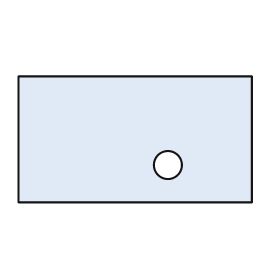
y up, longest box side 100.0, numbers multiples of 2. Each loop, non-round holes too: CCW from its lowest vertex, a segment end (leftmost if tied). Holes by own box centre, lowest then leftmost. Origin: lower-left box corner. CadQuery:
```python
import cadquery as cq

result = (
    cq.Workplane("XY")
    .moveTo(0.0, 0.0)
    .lineTo(100.0, 0.0)
    .lineTo(100.0, 54.0)
    .lineTo(0.0, 54.0)
    .close()
    .moveTo(64.0, 16.0)
    .circle(6.0)
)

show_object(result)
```